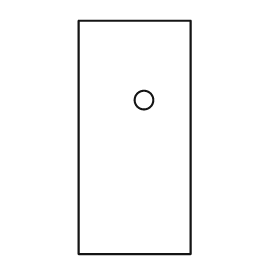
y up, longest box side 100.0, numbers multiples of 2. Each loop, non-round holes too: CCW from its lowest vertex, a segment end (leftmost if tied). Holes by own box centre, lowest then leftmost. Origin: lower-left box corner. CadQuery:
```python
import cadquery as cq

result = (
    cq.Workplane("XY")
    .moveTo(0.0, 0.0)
    .lineTo(48.0, 0.0)
    .lineTo(48.0, 100.0)
    .lineTo(0.0, 100.0)
    .close()
    .moveTo(28.0, 66.0)
    .circle(4.0)
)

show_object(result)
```